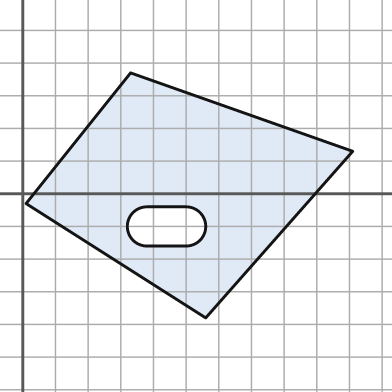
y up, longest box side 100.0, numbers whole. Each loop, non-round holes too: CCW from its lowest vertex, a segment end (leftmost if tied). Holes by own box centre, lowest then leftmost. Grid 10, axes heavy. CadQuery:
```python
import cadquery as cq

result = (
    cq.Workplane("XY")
    .moveTo(56.0, -38.0)
    .lineTo(101.0, 13.0)
    .lineTo(33.0, 37.0)
    .lineTo(1.0, -3.0)
    .close()
    .moveTo(38.0, -16.0)
    .lineTo(50.0, -16.0)
    .threePointArc((56.0, -10.0), (50.0, -4.0))
    .lineTo(38.0, -4.0)
    .threePointArc((32.0, -10.0), (38.0, -16.0))
    .close()
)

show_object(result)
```